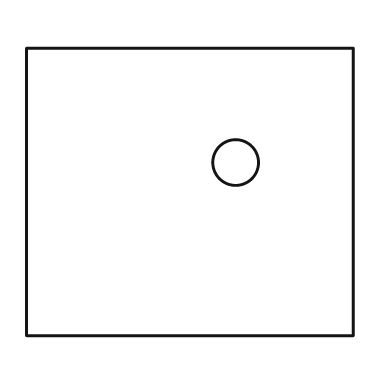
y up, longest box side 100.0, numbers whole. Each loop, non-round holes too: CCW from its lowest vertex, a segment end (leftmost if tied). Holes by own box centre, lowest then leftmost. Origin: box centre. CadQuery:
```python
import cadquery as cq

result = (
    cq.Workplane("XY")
    .moveTo(-50.0, -44.0)
    .lineTo(50.0, -44.0)
    .lineTo(50.0, 44.0)
    .lineTo(-50.0, 44.0)
    .close()
    .moveTo(14.0, 9.0)
    .circle(7.0)
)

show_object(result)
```